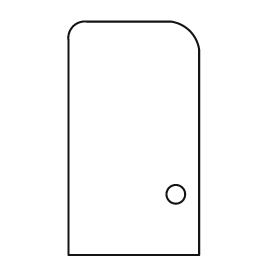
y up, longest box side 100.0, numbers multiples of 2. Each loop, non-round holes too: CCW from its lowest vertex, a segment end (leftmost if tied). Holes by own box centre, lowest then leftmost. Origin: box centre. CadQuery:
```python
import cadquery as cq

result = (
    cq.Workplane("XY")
    .moveTo(-28.0, -50.0)
    .lineTo(28.0, -50.0)
    .lineTo(28.0, 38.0)
    .threePointArc((24.0, 46.0), (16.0, 50.0))
    .lineTo(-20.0, 50.0)
    .threePointArc((-26.0, 48.0), (-28.0, 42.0))
    .close()
    .moveTo(18.0, -24.0)
    .circle(4.0)
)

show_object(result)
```